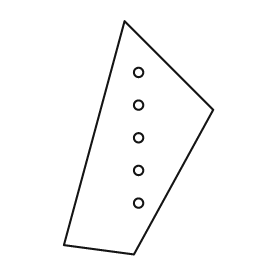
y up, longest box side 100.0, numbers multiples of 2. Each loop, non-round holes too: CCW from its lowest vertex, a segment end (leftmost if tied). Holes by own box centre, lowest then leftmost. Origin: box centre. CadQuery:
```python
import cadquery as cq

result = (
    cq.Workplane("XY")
    .moveTo(-2.0, -50.0)
    .lineTo(32.0, 12.0)
    .lineTo(-6.0, 50.0)
    .lineTo(-32.0, -46.0)
    .close()
    .moveTo(0.0, -28.0)
    .circle(2.0)
    .moveTo(0.0, -14.0)
    .circle(2.0)
    .moveTo(0.0, 0.0)
    .circle(2.0)
    .moveTo(0.0, 14.0)
    .circle(2.0)
    .moveTo(0.0, 28.0)
    .circle(2.0)
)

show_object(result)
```